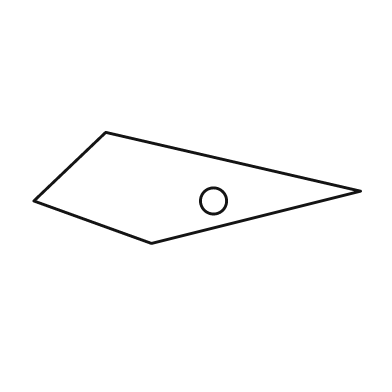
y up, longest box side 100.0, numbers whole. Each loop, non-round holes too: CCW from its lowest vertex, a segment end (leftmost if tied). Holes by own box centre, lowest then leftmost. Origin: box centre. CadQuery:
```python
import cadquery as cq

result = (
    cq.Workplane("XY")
    .moveTo(-14.0, -17.0)
    .lineTo(50.0, -1.0)
    .lineTo(-28.0, 17.0)
    .lineTo(-50.0, -4.0)
    .close()
    .moveTo(5.0, -4.0)
    .circle(4.0)
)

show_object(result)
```